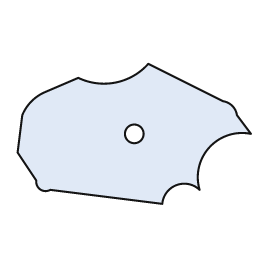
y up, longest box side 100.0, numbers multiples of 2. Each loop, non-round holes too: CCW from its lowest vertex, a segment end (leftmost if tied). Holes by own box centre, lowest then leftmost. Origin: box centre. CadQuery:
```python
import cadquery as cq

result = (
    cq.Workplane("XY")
    .moveTo(12.0, -30.0)
    .threePointArc((18.0, -22.0), (28.0, -24.0))
    .threePointArc((32.0, -6.0), (50.0, 0.0))
    .lineTo(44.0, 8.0)
    .threePointArc((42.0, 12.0), (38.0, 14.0))
    .lineTo(6.0, 30.0)
    .threePointArc((-8.0, 22.0), (-24.0, 24.0))
    .lineTo(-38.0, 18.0)
    .threePointArc((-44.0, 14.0), (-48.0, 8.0))
    .lineTo(-50.0, -8.0)
    .lineTo(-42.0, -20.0)
    .threePointArc((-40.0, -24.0), (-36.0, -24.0))
    .close()
    .moveTo(0.0, 0.0)
    .circle(4.0)
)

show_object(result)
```